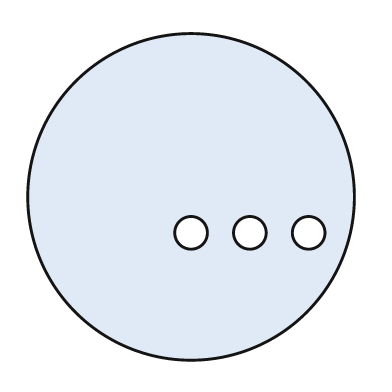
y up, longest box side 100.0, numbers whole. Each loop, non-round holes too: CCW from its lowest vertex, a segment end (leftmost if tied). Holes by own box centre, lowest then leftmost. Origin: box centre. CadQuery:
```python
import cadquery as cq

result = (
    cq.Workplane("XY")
    .moveTo(0.0, 0.0)
    .circle(50.0)
    .moveTo(0.0, -11.0)
    .circle(5.0)
    .moveTo(18.0, -11.0)
    .circle(5.0)
    .moveTo(36.0, -11.0)
    .circle(5.0)
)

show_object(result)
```